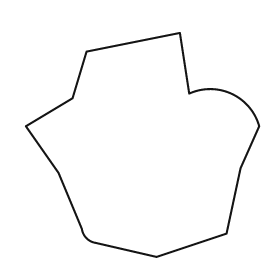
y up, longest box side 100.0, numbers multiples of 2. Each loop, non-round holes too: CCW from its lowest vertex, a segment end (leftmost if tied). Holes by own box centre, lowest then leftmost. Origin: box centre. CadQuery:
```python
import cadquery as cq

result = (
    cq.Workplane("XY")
    .moveTo(6.0, -48.0)
    .lineTo(36.0, -38.0)
    .lineTo(42.0, -10.0)
    .lineTo(50.0, 8.0)
    .threePointArc((38.0, 22.0), (20.0, 22.0))
    .lineTo(16.0, 48.0)
    .lineTo(-24.0, 40.0)
    .lineTo(-30.0, 20.0)
    .lineTo(-50.0, 8.0)
    .lineTo(-36.0, -12.0)
    .lineTo(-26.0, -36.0)
    .threePointArc((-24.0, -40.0), (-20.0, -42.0))
    .close()
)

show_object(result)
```